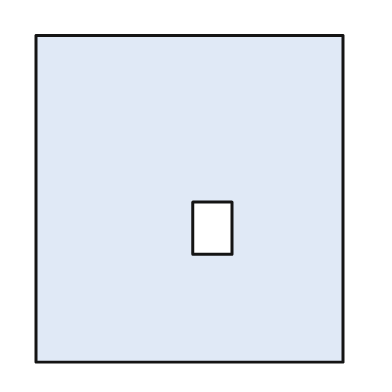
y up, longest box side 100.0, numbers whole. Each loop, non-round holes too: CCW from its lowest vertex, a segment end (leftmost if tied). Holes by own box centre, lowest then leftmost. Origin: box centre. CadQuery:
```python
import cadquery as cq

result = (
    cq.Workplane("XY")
    .moveTo(-47.0, -50.0)
    .lineTo(47.0, -50.0)
    .lineTo(47.0, 50.0)
    .lineTo(-47.0, 50.0)
    .close()
    .moveTo(1.0, -17.0)
    .lineTo(13.0, -17.0)
    .lineTo(13.0, -1.0)
    .lineTo(1.0, -1.0)
    .close()
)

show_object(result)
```